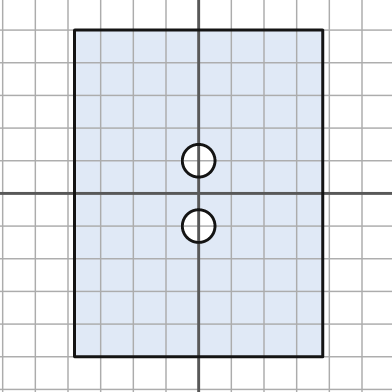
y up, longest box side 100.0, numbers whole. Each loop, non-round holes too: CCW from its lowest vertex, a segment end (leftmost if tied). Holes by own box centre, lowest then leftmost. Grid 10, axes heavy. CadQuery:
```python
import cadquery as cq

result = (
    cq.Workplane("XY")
    .moveTo(-38.0, -50.0)
    .lineTo(38.0, -50.0)
    .lineTo(38.0, 50.0)
    .lineTo(-38.0, 50.0)
    .close()
    .moveTo(0.0, -10.0)
    .circle(5.0)
    .moveTo(0.0, 10.0)
    .circle(5.0)
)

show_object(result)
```